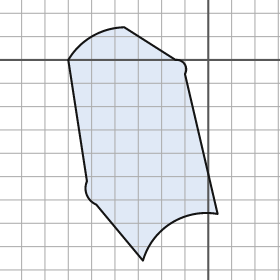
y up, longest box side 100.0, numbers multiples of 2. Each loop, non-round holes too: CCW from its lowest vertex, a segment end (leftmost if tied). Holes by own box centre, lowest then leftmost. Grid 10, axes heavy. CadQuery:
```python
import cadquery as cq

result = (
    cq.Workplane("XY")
    .moveTo(-28.0, -86.0)
    .threePointArc((-16.0, -70.0), (4.0, -66.0))
    .lineTo(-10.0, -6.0)
    .threePointArc((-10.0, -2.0), (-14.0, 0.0))
    .lineTo(-36.0, 14.0)
    .threePointArc((-50.0, 10.0), (-60.0, 0.0))
    .lineTo(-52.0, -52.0)
    .threePointArc((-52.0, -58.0), (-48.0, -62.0))
    .close()
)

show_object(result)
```